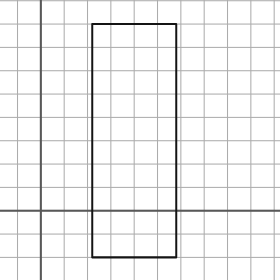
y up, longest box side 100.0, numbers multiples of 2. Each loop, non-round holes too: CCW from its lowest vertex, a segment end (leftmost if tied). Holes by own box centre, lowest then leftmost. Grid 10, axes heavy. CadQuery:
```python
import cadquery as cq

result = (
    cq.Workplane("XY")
    .moveTo(22.0, -20.0)
    .lineTo(58.0, -20.0)
    .lineTo(58.0, 80.0)
    .lineTo(22.0, 80.0)
    .close()
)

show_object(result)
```